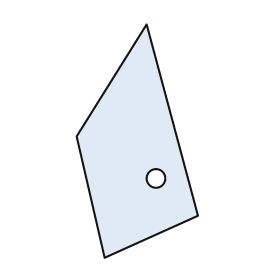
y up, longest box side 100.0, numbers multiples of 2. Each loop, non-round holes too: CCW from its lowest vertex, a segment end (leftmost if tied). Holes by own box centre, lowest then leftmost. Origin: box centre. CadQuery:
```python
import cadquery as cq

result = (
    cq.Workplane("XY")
    .moveTo(-14.0, -50.0)
    .lineTo(26.0, -32.0)
    .lineTo(4.0, 50.0)
    .lineTo(-26.0, 2.0)
    .close()
    .moveTo(8.0, -16.0)
    .circle(4.0)
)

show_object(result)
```